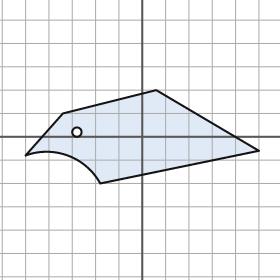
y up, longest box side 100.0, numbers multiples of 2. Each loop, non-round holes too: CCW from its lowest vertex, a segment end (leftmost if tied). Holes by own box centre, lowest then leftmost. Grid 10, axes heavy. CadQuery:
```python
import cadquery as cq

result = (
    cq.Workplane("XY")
    .moveTo(-18.0, -20.0)
    .lineTo(50.0, -6.0)
    .lineTo(6.0, 20.0)
    .lineTo(-34.0, 10.0)
    .lineTo(-50.0, -8.0)
    .threePointArc((-32.0, -8.0), (-18.0, -20.0))
    .close()
    .moveTo(-28.0, 2.0)
    .circle(2.0)
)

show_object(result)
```